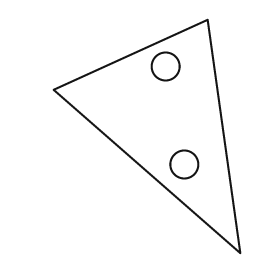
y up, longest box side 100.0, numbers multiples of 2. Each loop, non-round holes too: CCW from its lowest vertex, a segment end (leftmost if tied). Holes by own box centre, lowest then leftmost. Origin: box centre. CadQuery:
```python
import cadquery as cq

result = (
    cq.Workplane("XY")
    .moveTo(40.0, -50.0)
    .lineTo(26.0, 50.0)
    .lineTo(-40.0, 20.0)
    .close()
    .moveTo(16.0, -12.0)
    .circle(6.0)
    .moveTo(8.0, 30.0)
    .circle(6.0)
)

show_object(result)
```